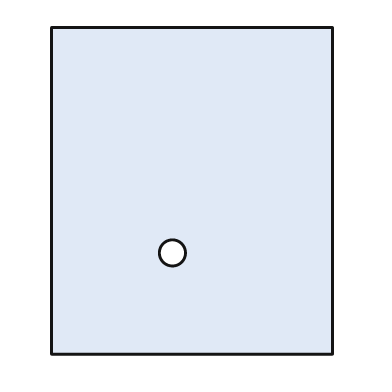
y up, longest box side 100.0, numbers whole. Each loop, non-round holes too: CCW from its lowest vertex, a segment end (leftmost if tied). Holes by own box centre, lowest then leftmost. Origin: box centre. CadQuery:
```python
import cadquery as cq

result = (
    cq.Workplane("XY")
    .moveTo(-43.0, -50.0)
    .lineTo(43.0, -50.0)
    .lineTo(43.0, 50.0)
    .lineTo(-43.0, 50.0)
    .close()
    .moveTo(-6.0, -19.0)
    .circle(4.0)
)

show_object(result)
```